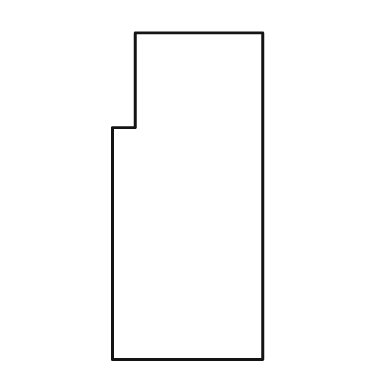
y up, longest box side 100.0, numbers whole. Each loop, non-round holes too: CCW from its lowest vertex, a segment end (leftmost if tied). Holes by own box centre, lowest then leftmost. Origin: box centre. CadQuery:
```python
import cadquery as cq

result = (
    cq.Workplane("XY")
    .moveTo(-23.0, -50.0)
    .lineTo(23.0, -50.0)
    .lineTo(23.0, 50.0)
    .lineTo(-16.0, 50.0)
    .lineTo(-16.0, 21.0)
    .lineTo(-23.0, 21.0)
    .close()
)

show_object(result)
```